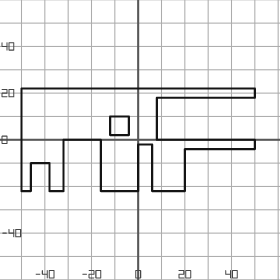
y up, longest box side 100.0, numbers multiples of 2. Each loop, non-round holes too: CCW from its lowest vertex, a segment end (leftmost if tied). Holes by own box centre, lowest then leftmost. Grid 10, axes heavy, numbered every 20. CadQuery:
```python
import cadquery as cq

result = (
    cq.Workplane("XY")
    .moveTo(-50.0, -22.0)
    .lineTo(-46.0, -22.0)
    .lineTo(-46.0, -10.0)
    .lineTo(-38.0, -10.0)
    .lineTo(-38.0, -22.0)
    .lineTo(-32.0, -22.0)
    .lineTo(-32.0, 0.0)
    .lineTo(-16.0, 0.0)
    .lineTo(-16.0, -22.0)
    .lineTo(0.0, -22.0)
    .lineTo(0.0, -2.0)
    .lineTo(6.0, -2.0)
    .lineTo(6.0, -22.0)
    .lineTo(20.0, -22.0)
    .lineTo(20.0, -4.0)
    .lineTo(50.0, -4.0)
    .lineTo(50.0, 0.0)
    .lineTo(8.0, 0.0)
    .lineTo(8.0, 18.0)
    .lineTo(50.0, 18.0)
    .lineTo(50.0, 22.0)
    .lineTo(-50.0, 22.0)
    .close()
    .moveTo(-12.0, 2.0)
    .lineTo(-4.0, 2.0)
    .lineTo(-4.0, 10.0)
    .lineTo(-12.0, 10.0)
    .close()
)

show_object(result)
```